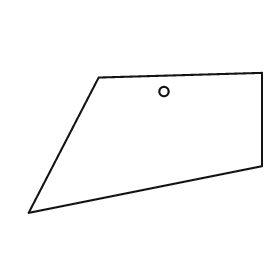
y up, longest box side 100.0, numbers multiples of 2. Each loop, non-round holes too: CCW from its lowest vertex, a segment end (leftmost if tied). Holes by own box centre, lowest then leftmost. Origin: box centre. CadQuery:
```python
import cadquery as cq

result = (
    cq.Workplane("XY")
    .moveTo(-50.0, -30.0)
    .lineTo(50.0, -10.0)
    .lineTo(50.0, 30.0)
    .lineTo(-20.0, 28.0)
    .close()
    .moveTo(8.0, 22.0)
    .circle(2.0)
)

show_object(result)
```